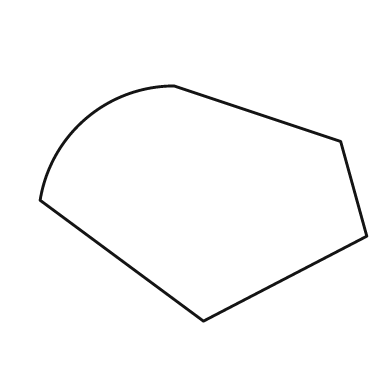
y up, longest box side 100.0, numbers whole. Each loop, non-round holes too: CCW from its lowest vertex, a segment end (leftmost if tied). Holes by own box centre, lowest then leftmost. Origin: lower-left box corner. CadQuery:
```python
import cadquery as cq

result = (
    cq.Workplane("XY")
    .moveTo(50.0, 0.0)
    .lineTo(100.0, 26.0)
    .lineTo(92.0, 55.0)
    .lineTo(41.0, 72.0)
    .threePointArc((14.0, 62.0), (0.0, 37.0))
    .close()
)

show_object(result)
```